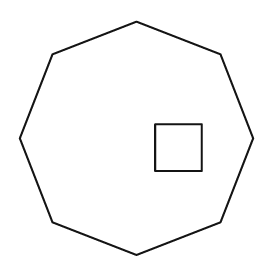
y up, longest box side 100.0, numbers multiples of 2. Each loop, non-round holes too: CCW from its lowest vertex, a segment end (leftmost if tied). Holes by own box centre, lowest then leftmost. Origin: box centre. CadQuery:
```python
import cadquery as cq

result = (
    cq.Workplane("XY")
    .moveTo(0.0, -50.0)
    .lineTo(36.0, -36.0)
    .lineTo(50.0, 0.0)
    .lineTo(36.0, 36.0)
    .lineTo(0.0, 50.0)
    .lineTo(-36.0, 36.0)
    .lineTo(-50.0, 0.0)
    .lineTo(-36.0, -36.0)
    .close()
    .moveTo(8.0, -14.0)
    .lineTo(28.0, -14.0)
    .lineTo(28.0, 6.0)
    .lineTo(8.0, 6.0)
    .close()
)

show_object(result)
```